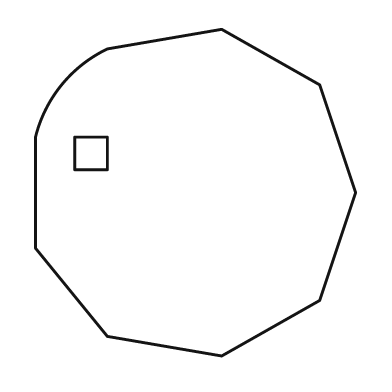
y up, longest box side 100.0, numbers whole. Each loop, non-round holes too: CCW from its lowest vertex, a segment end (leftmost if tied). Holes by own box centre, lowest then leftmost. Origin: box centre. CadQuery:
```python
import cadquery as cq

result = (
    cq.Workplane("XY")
    .moveTo(8.0, -50.0)
    .lineTo(38.0, -33.0)
    .lineTo(49.0, 0.0)
    .lineTo(38.0, 33.0)
    .lineTo(8.0, 50.0)
    .lineTo(-27.0, 44.0)
    .threePointArc((-41.0, 33.0), (-49.0, 17.0))
    .lineTo(-49.0, -17.0)
    .lineTo(-27.0, -44.0)
    .close()
    .moveTo(-37.0, 7.0)
    .lineTo(-27.0, 7.0)
    .lineTo(-27.0, 17.0)
    .lineTo(-37.0, 17.0)
    .close()
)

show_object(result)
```